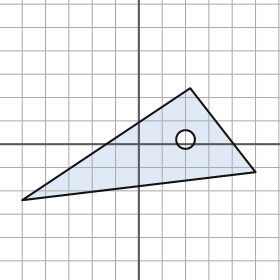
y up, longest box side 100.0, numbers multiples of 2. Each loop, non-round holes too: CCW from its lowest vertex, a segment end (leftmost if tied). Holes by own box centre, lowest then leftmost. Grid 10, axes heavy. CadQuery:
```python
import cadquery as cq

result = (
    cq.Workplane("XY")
    .moveTo(-50.0, -24.0)
    .lineTo(50.0, -12.0)
    .lineTo(22.0, 24.0)
    .close()
    .moveTo(20.0, 2.0)
    .circle(4.0)
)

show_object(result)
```